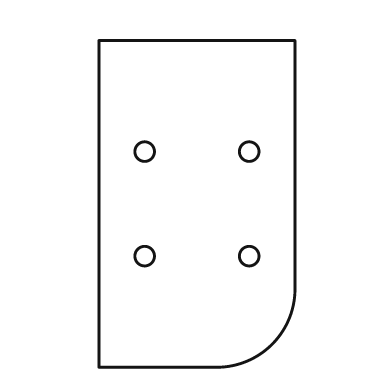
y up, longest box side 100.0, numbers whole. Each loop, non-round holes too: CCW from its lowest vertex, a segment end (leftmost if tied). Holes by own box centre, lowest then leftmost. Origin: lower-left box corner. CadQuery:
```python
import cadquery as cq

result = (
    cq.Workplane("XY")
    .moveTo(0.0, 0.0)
    .lineTo(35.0, 0.0)
    .threePointArc((53.0, 7.0), (60.0, 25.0))
    .lineTo(60.0, 100.0)
    .lineTo(0.0, 100.0)
    .close()
    .moveTo(14.0, 34.0)
    .circle(3.0)
    .moveTo(46.0, 34.0)
    .circle(3.0)
    .moveTo(14.0, 66.0)
    .circle(3.0)
    .moveTo(46.0, 66.0)
    .circle(3.0)
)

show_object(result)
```